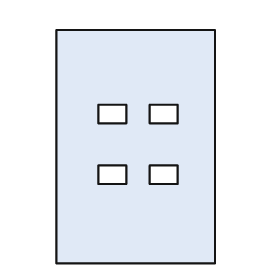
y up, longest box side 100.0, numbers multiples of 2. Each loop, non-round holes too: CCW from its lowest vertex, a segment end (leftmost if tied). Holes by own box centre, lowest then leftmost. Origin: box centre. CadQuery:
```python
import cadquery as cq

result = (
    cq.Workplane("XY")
    .moveTo(-34.0, -50.0)
    .lineTo(34.0, -50.0)
    .lineTo(34.0, 50.0)
    .lineTo(-34.0, 50.0)
    .close()
    .moveTo(-16.0, -16.0)
    .lineTo(-4.0, -16.0)
    .lineTo(-4.0, -8.0)
    .lineTo(-16.0, -8.0)
    .close()
    .moveTo(6.0, -16.0)
    .lineTo(18.0, -16.0)
    .lineTo(18.0, -8.0)
    .lineTo(6.0, -8.0)
    .close()
    .moveTo(-16.0, 10.0)
    .lineTo(-4.0, 10.0)
    .lineTo(-4.0, 18.0)
    .lineTo(-16.0, 18.0)
    .close()
    .moveTo(6.0, 10.0)
    .lineTo(18.0, 10.0)
    .lineTo(18.0, 18.0)
    .lineTo(6.0, 18.0)
    .close()
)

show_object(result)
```